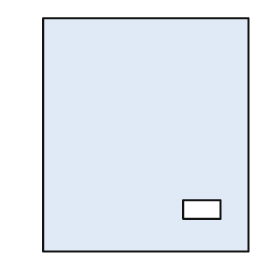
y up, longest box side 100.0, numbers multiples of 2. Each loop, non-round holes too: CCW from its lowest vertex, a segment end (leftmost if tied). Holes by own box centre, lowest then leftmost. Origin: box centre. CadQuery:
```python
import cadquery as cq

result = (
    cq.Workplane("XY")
    .moveTo(-44.0, -50.0)
    .lineTo(44.0, -50.0)
    .lineTo(44.0, 50.0)
    .lineTo(-44.0, 50.0)
    .close()
    .moveTo(16.0, -36.0)
    .lineTo(32.0, -36.0)
    .lineTo(32.0, -28.0)
    .lineTo(16.0, -28.0)
    .close()
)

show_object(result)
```